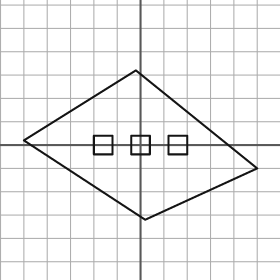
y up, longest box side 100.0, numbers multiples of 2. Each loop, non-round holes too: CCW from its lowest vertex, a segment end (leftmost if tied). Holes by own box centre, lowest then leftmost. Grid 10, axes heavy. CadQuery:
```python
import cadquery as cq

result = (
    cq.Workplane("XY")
    .moveTo(2.0, -32.0)
    .lineTo(50.0, -10.0)
    .lineTo(-2.0, 32.0)
    .lineTo(-50.0, 2.0)
    .close()
    .moveTo(-20.0, -4.0)
    .lineTo(-12.0, -4.0)
    .lineTo(-12.0, 4.0)
    .lineTo(-20.0, 4.0)
    .close()
    .moveTo(-4.0, -4.0)
    .lineTo(4.0, -4.0)
    .lineTo(4.0, 4.0)
    .lineTo(-4.0, 4.0)
    .close()
    .moveTo(12.0, -4.0)
    .lineTo(20.0, -4.0)
    .lineTo(20.0, 4.0)
    .lineTo(12.0, 4.0)
    .close()
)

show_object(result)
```